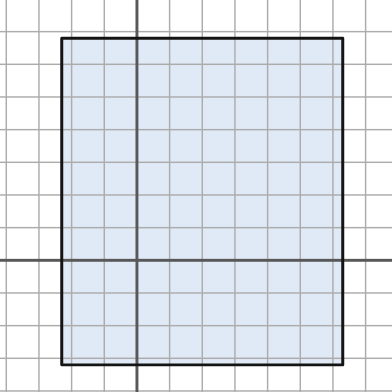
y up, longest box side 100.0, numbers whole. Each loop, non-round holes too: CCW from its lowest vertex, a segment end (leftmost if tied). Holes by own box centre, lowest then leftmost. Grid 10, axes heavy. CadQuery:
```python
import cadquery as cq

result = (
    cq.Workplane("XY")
    .moveTo(-23.0, -32.0)
    .lineTo(63.0, -32.0)
    .lineTo(63.0, 68.0)
    .lineTo(-23.0, 68.0)
    .close()
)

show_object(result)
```